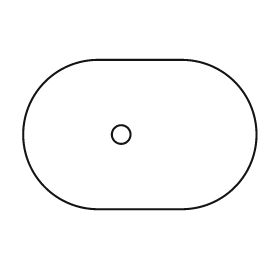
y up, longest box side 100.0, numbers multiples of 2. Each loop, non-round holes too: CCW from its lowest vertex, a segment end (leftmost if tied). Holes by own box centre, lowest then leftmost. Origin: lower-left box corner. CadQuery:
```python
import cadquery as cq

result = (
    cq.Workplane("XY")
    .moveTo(32.0, 0.0)
    .lineTo(68.0, 0.0)
    .threePointArc((100.0, 32.0), (68.0, 64.0))
    .lineTo(32.0, 64.0)
    .threePointArc((0.0, 32.0), (32.0, 0.0))
    .close()
    .moveTo(42.0, 32.0)
    .circle(4.0)
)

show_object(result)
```